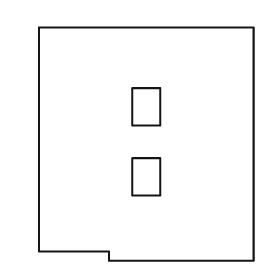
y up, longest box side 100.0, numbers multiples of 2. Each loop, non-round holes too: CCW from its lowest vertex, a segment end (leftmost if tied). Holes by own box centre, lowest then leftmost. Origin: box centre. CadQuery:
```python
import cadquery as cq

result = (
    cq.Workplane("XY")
    .moveTo(-16.0, -50.0)
    .lineTo(46.0, -50.0)
    .lineTo(46.0, 50.0)
    .lineTo(-46.0, 50.0)
    .lineTo(-46.0, -46.0)
    .lineTo(-16.0, -46.0)
    .close()
    .moveTo(-6.0, -22.0)
    .lineTo(6.0, -22.0)
    .lineTo(6.0, -6.0)
    .lineTo(-6.0, -6.0)
    .close()
    .moveTo(-6.0, 8.0)
    .lineTo(6.0, 8.0)
    .lineTo(6.0, 24.0)
    .lineTo(-6.0, 24.0)
    .close()
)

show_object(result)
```